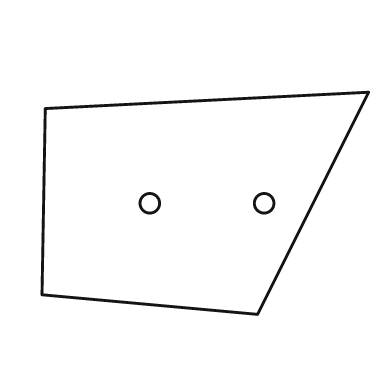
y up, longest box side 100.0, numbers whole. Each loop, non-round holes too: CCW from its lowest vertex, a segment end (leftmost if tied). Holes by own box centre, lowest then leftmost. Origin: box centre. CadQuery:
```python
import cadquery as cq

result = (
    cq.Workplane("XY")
    .moveTo(16.0, -34.0)
    .lineTo(50.0, 34.0)
    .lineTo(-49.0, 29.0)
    .lineTo(-50.0, -28.0)
    .close()
    .moveTo(-17.0, 0.0)
    .circle(3.0)
    .moveTo(18.0, 0.0)
    .circle(3.0)
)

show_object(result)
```